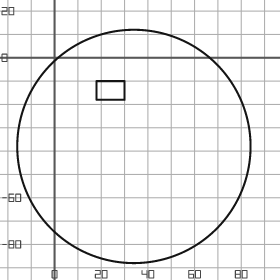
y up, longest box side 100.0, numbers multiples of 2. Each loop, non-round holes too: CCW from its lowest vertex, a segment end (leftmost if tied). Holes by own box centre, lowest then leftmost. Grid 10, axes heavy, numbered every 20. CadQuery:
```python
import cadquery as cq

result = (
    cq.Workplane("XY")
    .moveTo(34.0, -38.0)
    .circle(50.0)
    .moveTo(18.0, -18.0)
    .lineTo(30.0, -18.0)
    .lineTo(30.0, -10.0)
    .lineTo(18.0, -10.0)
    .close()
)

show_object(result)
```